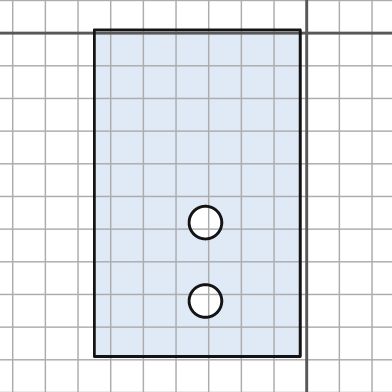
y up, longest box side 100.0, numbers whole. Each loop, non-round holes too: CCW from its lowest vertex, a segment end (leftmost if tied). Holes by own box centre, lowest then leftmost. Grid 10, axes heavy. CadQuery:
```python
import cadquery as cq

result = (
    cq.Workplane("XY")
    .moveTo(-65.0, -99.0)
    .lineTo(-2.0, -99.0)
    .lineTo(-2.0, 1.0)
    .lineTo(-65.0, 1.0)
    .close()
    .moveTo(-31.0, -82.0)
    .circle(5.0)
    .moveTo(-31.0, -58.0)
    .circle(5.0)
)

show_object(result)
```